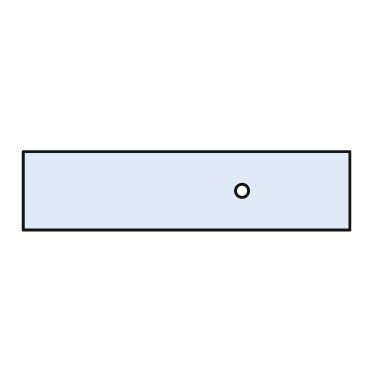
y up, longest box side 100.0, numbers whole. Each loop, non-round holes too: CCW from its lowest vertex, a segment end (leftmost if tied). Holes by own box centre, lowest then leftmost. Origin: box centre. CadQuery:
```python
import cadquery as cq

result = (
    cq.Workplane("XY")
    .moveTo(-50.0, -12.0)
    .lineTo(50.0, -12.0)
    .lineTo(50.0, 12.0)
    .lineTo(-50.0, 12.0)
    .close()
    .moveTo(17.0, 0.0)
    .circle(2.0)
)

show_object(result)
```